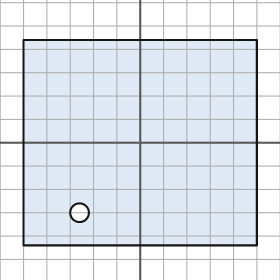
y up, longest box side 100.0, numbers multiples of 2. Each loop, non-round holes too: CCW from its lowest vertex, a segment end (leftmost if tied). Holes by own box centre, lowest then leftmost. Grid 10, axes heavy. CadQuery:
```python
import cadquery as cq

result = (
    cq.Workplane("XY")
    .moveTo(-50.0, -44.0)
    .lineTo(50.0, -44.0)
    .lineTo(50.0, 44.0)
    .lineTo(-50.0, 44.0)
    .close()
    .moveTo(-26.0, -30.0)
    .circle(4.0)
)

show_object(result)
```